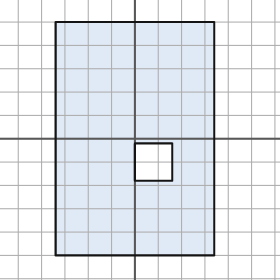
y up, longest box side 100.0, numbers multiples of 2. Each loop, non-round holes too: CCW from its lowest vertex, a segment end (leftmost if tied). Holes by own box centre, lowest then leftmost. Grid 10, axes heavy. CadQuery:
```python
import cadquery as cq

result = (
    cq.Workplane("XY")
    .moveTo(-34.0, -50.0)
    .lineTo(34.0, -50.0)
    .lineTo(34.0, 50.0)
    .lineTo(-34.0, 50.0)
    .close()
    .moveTo(0.0, -18.0)
    .lineTo(16.0, -18.0)
    .lineTo(16.0, -2.0)
    .lineTo(0.0, -2.0)
    .close()
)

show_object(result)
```